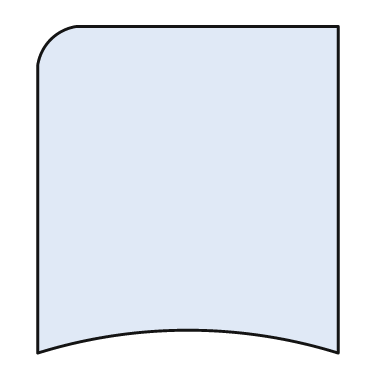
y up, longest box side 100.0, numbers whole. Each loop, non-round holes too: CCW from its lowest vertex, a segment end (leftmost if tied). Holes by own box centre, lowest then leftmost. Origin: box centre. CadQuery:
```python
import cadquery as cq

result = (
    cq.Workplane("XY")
    .moveTo(-46.0, -50.0)
    .threePointArc((0.0, -43.0), (46.0, -50.0))
    .lineTo(46.0, 50.0)
    .lineTo(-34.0, 50.0)
    .threePointArc((-42.0, 46.0), (-46.0, 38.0))
    .close()
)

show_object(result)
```